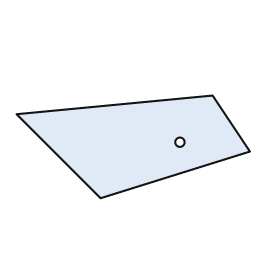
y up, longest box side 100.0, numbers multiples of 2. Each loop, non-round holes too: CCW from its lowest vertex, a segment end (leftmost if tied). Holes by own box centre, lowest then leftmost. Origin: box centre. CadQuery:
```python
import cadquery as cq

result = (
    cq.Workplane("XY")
    .moveTo(-14.0, -22.0)
    .lineTo(50.0, -2.0)
    .lineTo(34.0, 22.0)
    .lineTo(-50.0, 14.0)
    .close()
    .moveTo(20.0, 2.0)
    .circle(2.0)
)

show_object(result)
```